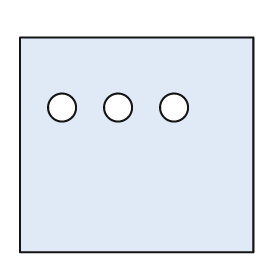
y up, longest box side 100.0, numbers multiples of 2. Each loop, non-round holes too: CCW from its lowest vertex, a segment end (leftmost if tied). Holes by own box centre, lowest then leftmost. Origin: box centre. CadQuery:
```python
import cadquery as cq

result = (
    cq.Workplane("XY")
    .moveTo(-50.0, -46.0)
    .lineTo(50.0, -46.0)
    .lineTo(50.0, 46.0)
    .lineTo(-50.0, 46.0)
    .close()
    .moveTo(-32.0, 16.0)
    .circle(6.0)
    .moveTo(-8.0, 16.0)
    .circle(6.0)
    .moveTo(16.0, 16.0)
    .circle(6.0)
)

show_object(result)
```